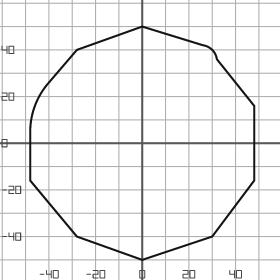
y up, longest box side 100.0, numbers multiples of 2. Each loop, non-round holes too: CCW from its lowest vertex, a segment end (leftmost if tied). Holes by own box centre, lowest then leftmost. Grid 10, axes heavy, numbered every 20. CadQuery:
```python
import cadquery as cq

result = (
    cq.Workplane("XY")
    .moveTo(0.0, -50.0)
    .lineTo(30.0, -40.0)
    .lineTo(48.0, -16.0)
    .lineTo(48.0, 16.0)
    .lineTo(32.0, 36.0)
    .threePointArc((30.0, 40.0), (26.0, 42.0))
    .lineTo(0.0, 50.0)
    .lineTo(-28.0, 40.0)
    .lineTo(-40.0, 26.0)
    .threePointArc((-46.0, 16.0), (-48.0, 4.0))
    .lineTo(-48.0, -16.0)
    .lineTo(-28.0, -40.0)
    .close()
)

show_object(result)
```